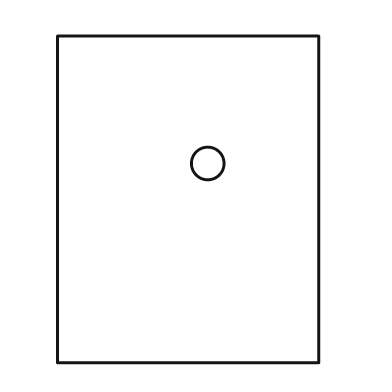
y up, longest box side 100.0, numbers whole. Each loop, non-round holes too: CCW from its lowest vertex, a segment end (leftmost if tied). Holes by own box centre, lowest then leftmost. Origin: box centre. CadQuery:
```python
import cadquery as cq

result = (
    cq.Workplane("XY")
    .moveTo(-40.0, -50.0)
    .lineTo(40.0, -50.0)
    .lineTo(40.0, 50.0)
    .lineTo(-40.0, 50.0)
    .close()
    .moveTo(6.0, 11.0)
    .circle(5.0)
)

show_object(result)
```